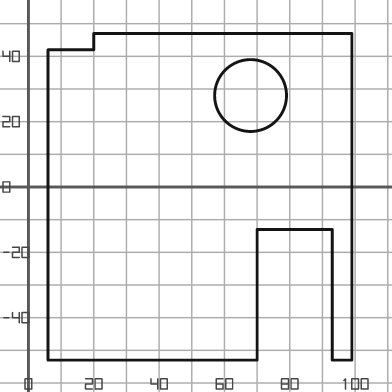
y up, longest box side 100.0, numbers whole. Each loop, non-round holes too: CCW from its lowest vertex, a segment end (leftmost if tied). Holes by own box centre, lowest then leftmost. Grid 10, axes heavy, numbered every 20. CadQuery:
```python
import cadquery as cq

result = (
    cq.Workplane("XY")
    .moveTo(6.0, -53.0)
    .lineTo(70.0, -53.0)
    .lineTo(70.0, -13.0)
    .lineTo(93.0, -13.0)
    .lineTo(93.0, -53.0)
    .lineTo(99.0, -53.0)
    .lineTo(99.0, 47.0)
    .lineTo(20.0, 47.0)
    .lineTo(20.0, 42.0)
    .lineTo(6.0, 42.0)
    .close()
    .moveTo(68.0, 28.0)
    .circle(11.0)
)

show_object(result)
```